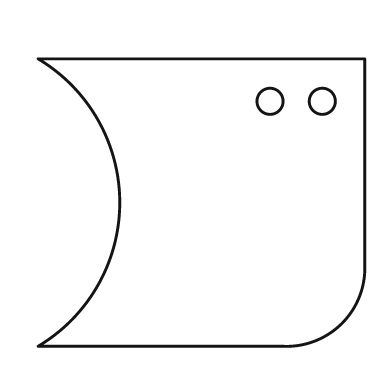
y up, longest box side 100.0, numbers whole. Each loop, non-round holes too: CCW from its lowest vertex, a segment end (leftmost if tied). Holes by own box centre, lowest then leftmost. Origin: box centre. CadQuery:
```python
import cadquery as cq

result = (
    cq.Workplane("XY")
    .moveTo(-50.0, -44.0)
    .lineTo(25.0, -44.0)
    .threePointArc((43.0, -37.0), (50.0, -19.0))
    .lineTo(50.0, 44.0)
    .lineTo(-50.0, 44.0)
    .threePointArc((-25.0, 0.0), (-50.0, -44.0))
    .close()
    .moveTo(21.0, 31.0)
    .circle(4.0)
    .moveTo(37.0, 31.0)
    .circle(4.0)
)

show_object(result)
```